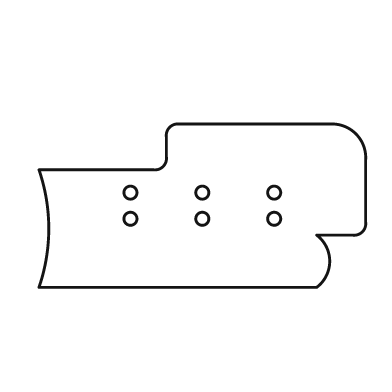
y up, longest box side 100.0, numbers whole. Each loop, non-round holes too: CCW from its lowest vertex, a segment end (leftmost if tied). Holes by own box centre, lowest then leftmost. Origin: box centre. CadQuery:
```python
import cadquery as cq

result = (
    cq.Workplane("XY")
    .moveTo(-50.0, -25.0)
    .lineTo(35.0, -25.0)
    .threePointArc((39.0, -17.0), (35.0, -9.0))
    .lineTo(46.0, -9.0)
    .threePointArc((49.0, -8.0), (50.0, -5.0))
    .lineTo(50.0, 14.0)
    .threePointArc((47.0, 22.0), (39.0, 25.0))
    .lineTo(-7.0, 25.0)
    .threePointArc((-10.0, 24.0), (-11.0, 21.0))
    .lineTo(-11.0, 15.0)
    .threePointArc((-12.0, 12.0), (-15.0, 11.0))
    .lineTo(-50.0, 11.0)
    .threePointArc((-47.0, -7.0), (-50.0, -25.0))
    .close()
    .moveTo(-22.0, -4.0)
    .circle(2.0)
    .moveTo(0.0, -4.0)
    .circle(2.0)
    .moveTo(22.0, -4.0)
    .circle(2.0)
    .moveTo(-22.0, 4.0)
    .circle(2.0)
    .moveTo(0.0, 4.0)
    .circle(2.0)
    .moveTo(22.0, 4.0)
    .circle(2.0)
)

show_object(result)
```